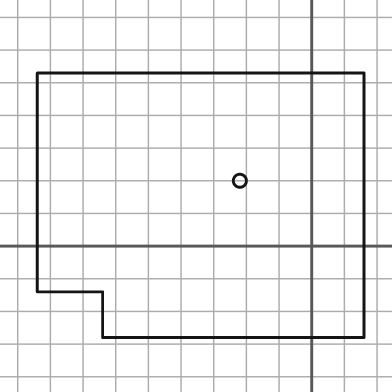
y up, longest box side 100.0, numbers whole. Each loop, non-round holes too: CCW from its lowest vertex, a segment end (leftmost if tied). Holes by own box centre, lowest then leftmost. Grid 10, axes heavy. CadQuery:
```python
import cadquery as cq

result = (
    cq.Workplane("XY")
    .moveTo(-64.0, -28.0)
    .lineTo(16.0, -28.0)
    .lineTo(16.0, 53.0)
    .lineTo(-84.0, 53.0)
    .lineTo(-84.0, -14.0)
    .lineTo(-64.0, -14.0)
    .close()
    .moveTo(-22.0, 20.0)
    .circle(2.0)
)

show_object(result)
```